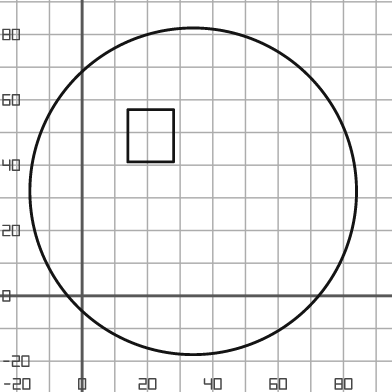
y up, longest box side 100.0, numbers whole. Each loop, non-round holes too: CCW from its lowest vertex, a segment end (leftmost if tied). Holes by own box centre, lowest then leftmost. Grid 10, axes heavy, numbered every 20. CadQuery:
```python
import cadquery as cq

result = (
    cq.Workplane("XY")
    .moveTo(34.0, 32.0)
    .circle(50.0)
    .moveTo(14.0, 41.0)
    .lineTo(28.0, 41.0)
    .lineTo(28.0, 57.0)
    .lineTo(14.0, 57.0)
    .close()
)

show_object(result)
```